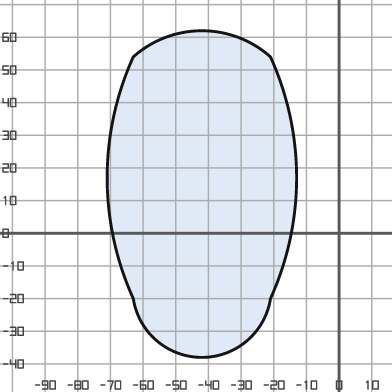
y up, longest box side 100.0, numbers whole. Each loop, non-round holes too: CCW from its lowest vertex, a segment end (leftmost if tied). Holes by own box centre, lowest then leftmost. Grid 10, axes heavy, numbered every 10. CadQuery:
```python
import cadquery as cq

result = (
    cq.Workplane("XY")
    .moveTo(-63.0, -20.0)
    .threePointArc((-42.0, -38.0), (-21.0, -20.0))
    .threePointArc((-13.0, 17.0), (-21.0, 54.0))
    .threePointArc((-42.0, 62.0), (-63.0, 54.0))
    .threePointArc((-71.0, 17.0), (-63.0, -20.0))
    .close()
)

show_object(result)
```